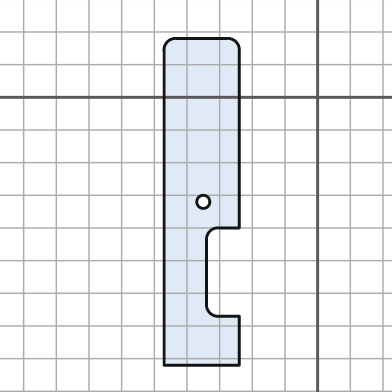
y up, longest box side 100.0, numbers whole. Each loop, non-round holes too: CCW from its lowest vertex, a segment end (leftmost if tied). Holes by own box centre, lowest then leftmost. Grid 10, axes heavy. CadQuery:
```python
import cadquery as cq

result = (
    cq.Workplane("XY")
    .moveTo(-47.0, -82.0)
    .lineTo(-24.0, -82.0)
    .lineTo(-24.0, -67.0)
    .lineTo(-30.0, -67.0)
    .threePointArc((-33.0, -66.0), (-34.0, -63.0))
    .lineTo(-34.0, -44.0)
    .threePointArc((-33.0, -41.0), (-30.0, -40.0))
    .lineTo(-24.0, -40.0)
    .lineTo(-24.0, 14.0)
    .threePointArc((-25.0, 17.0), (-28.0, 18.0))
    .lineTo(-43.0, 18.0)
    .threePointArc((-46.0, 17.0), (-47.0, 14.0))
    .close()
    .moveTo(-35.0, -32.0)
    .circle(2.0)
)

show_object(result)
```